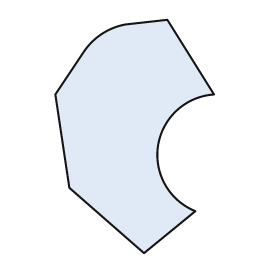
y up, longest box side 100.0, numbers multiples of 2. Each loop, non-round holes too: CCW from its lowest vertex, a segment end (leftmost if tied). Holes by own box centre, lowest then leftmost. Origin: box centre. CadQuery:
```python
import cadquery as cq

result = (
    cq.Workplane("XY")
    .moveTo(4.0, -50.0)
    .lineTo(26.0, -32.0)
    .threePointArc((10.0, -4.0), (34.0, 18.0))
    .lineTo(14.0, 50.0)
    .lineTo(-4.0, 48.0)
    .threePointArc((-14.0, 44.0), (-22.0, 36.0))
    .lineTo(-34.0, 18.0)
    .lineTo(-28.0, -22.0)
    .close()
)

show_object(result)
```